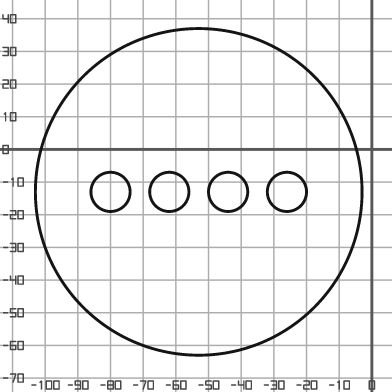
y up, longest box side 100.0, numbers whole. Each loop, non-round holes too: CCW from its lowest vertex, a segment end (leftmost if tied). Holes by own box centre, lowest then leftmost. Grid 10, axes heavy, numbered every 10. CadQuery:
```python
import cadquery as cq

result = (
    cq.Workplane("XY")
    .moveTo(-53.0, -13.0)
    .circle(50.0)
    .moveTo(-80.0, -13.0)
    .circle(6.0)
    .moveTo(-62.0, -13.0)
    .circle(6.0)
    .moveTo(-44.0, -13.0)
    .circle(6.0)
    .moveTo(-26.0, -13.0)
    .circle(6.0)
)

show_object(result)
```